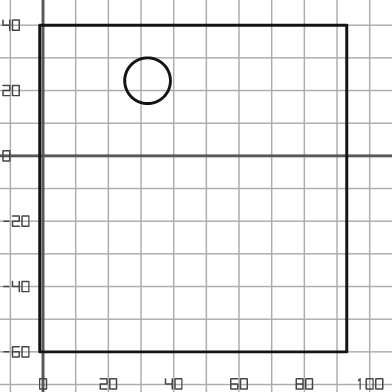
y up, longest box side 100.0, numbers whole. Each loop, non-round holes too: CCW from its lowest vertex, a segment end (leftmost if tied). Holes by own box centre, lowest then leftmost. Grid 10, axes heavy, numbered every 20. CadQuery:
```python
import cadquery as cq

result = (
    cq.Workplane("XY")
    .moveTo(-1.0, -60.0)
    .lineTo(93.0, -60.0)
    .lineTo(93.0, 40.0)
    .lineTo(-1.0, 40.0)
    .close()
    .moveTo(32.0, 23.0)
    .circle(7.0)
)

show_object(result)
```